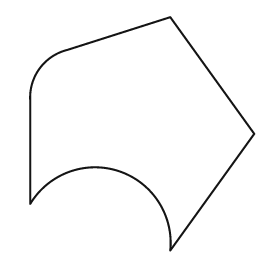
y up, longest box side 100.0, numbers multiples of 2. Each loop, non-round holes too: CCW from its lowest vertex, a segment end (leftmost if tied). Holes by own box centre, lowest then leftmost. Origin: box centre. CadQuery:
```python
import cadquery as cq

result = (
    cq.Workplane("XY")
    .moveTo(12.0, -50.0)
    .lineTo(48.0, 0.0)
    .lineTo(12.0, 50.0)
    .lineTo(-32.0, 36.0)
    .threePointArc((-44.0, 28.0), (-48.0, 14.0))
    .lineTo(-48.0, -30.0)
    .threePointArc((-10.0, -16.0), (12.0, -50.0))
    .close()
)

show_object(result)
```